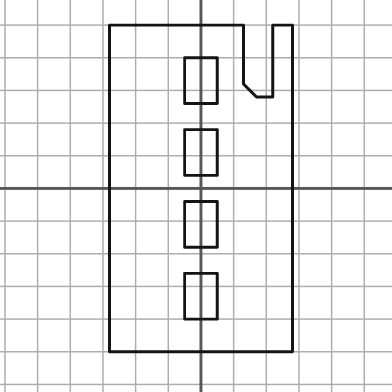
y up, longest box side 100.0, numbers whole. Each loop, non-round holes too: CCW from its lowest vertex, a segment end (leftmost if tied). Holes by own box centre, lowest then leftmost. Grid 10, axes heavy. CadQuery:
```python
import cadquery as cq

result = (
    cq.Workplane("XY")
    .moveTo(-28.0, -50.0)
    .lineTo(28.0, -50.0)
    .lineTo(28.0, 50.0)
    .lineTo(22.0, 50.0)
    .lineTo(22.0, 28.0)
    .lineTo(17.0, 28.0)
    .lineTo(13.0, 32.0)
    .lineTo(13.0, 50.0)
    .lineTo(-28.0, 50.0)
    .close()
    .moveTo(-5.0, -40.0)
    .lineTo(5.0, -40.0)
    .lineTo(5.0, -26.0)
    .lineTo(-5.0, -26.0)
    .close()
    .moveTo(-5.0, -18.0)
    .lineTo(5.0, -18.0)
    .lineTo(5.0, -4.0)
    .lineTo(-5.0, -4.0)
    .close()
    .moveTo(-5.0, 4.0)
    .lineTo(5.0, 4.0)
    .lineTo(5.0, 18.0)
    .lineTo(-5.0, 18.0)
    .close()
    .moveTo(-5.0, 26.0)
    .lineTo(5.0, 26.0)
    .lineTo(5.0, 40.0)
    .lineTo(-5.0, 40.0)
    .close()
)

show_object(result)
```